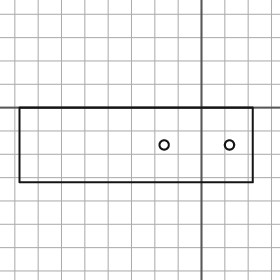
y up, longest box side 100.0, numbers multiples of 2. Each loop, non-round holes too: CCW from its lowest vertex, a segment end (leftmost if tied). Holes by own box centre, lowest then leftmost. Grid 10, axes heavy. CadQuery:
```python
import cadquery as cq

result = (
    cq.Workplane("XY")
    .moveTo(-78.0, -32.0)
    .lineTo(22.0, -32.0)
    .lineTo(22.0, 0.0)
    .lineTo(-78.0, 0.0)
    .close()
    .moveTo(-16.0, -16.0)
    .circle(2.0)
    .moveTo(12.0, -16.0)
    .circle(2.0)
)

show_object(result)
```